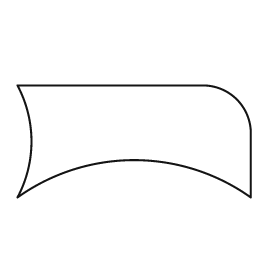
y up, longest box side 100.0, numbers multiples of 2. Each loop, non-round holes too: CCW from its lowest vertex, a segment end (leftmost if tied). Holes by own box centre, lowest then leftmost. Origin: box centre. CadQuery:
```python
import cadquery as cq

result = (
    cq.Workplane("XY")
    .moveTo(-50.0, -24.0)
    .threePointArc((0.0, -8.0), (50.0, -24.0))
    .lineTo(50.0, 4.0)
    .threePointArc((44.0, 18.0), (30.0, 24.0))
    .lineTo(-50.0, 24.0)
    .threePointArc((-44.0, 0.0), (-50.0, -24.0))
    .close()
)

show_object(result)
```